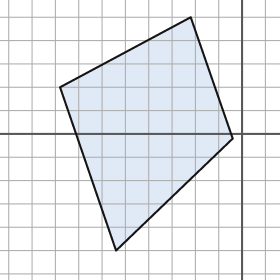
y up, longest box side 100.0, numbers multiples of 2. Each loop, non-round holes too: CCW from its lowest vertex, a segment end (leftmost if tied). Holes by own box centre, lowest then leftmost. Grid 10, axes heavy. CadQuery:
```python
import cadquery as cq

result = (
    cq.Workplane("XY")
    .moveTo(-54.0, -50.0)
    .lineTo(-4.0, -2.0)
    .lineTo(-22.0, 50.0)
    .lineTo(-78.0, 20.0)
    .close()
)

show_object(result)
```